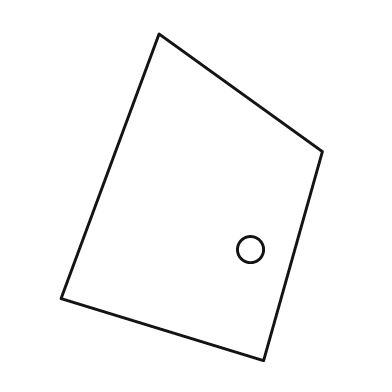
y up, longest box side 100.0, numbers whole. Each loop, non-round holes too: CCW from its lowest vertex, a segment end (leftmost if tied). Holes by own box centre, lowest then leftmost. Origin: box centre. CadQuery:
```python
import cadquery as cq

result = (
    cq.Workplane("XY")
    .moveTo(22.0, -50.0)
    .lineTo(40.0, 14.0)
    .lineTo(-10.0, 50.0)
    .lineTo(-40.0, -31.0)
    .close()
    .moveTo(18.0, -16.0)
    .circle(4.0)
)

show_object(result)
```